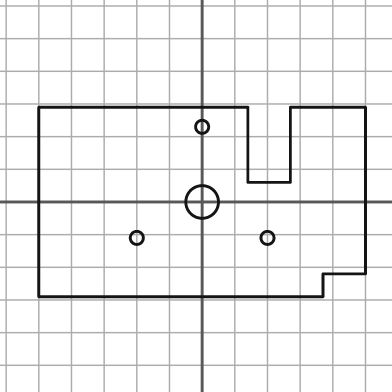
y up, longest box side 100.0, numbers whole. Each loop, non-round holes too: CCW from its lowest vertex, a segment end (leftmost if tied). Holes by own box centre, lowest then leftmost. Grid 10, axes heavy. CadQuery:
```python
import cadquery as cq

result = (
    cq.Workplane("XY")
    .moveTo(-50.0, -29.0)
    .lineTo(37.0, -29.0)
    .lineTo(37.0, -22.0)
    .lineTo(50.0, -22.0)
    .lineTo(50.0, 29.0)
    .lineTo(27.0, 29.0)
    .lineTo(27.0, 6.0)
    .lineTo(14.0, 6.0)
    .lineTo(14.0, 29.0)
    .lineTo(-50.0, 29.0)
    .close()
    .moveTo(-20.0, -11.0)
    .circle(2.0)
    .moveTo(20.0, -11.0)
    .circle(2.0)
    .moveTo(0.0, 0.0)
    .circle(5.0)
    .moveTo(0.0, 23.0)
    .circle(2.0)
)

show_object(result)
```